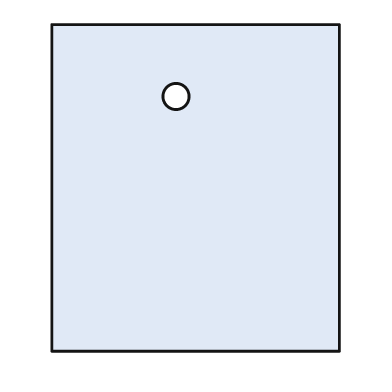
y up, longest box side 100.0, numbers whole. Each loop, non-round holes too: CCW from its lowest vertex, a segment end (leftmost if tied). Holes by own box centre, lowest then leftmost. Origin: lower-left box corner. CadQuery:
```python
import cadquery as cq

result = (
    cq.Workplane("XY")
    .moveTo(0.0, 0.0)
    .lineTo(88.0, 0.0)
    .lineTo(88.0, 100.0)
    .lineTo(0.0, 100.0)
    .close()
    .moveTo(38.0, 78.0)
    .circle(4.0)
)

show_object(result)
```